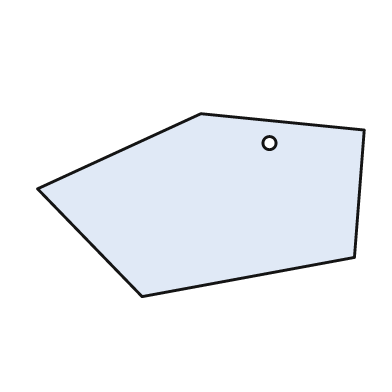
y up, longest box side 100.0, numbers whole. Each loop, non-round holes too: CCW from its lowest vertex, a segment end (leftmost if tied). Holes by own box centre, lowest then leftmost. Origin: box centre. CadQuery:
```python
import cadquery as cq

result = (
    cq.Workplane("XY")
    .moveTo(-18.0, -28.0)
    .lineTo(47.0, -16.0)
    .lineTo(50.0, 23.0)
    .lineTo(0.0, 28.0)
    .lineTo(-50.0, 5.0)
    .close()
    .moveTo(21.0, 19.0)
    .circle(2.0)
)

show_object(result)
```